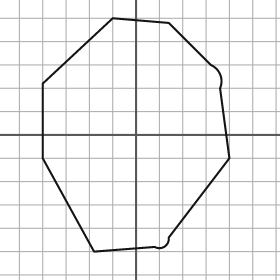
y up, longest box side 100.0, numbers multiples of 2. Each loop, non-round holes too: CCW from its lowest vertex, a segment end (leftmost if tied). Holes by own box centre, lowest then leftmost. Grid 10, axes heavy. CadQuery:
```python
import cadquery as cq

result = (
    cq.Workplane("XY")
    .moveTo(-18.0, -50.0)
    .lineTo(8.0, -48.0)
    .threePointArc((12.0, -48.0), (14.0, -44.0))
    .lineTo(40.0, -10.0)
    .lineTo(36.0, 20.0)
    .threePointArc((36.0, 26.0), (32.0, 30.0))
    .lineTo(14.0, 48.0)
    .lineTo(-10.0, 50.0)
    .lineTo(-40.0, 22.0)
    .lineTo(-40.0, -10.0)
    .close()
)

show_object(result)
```